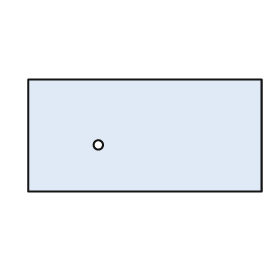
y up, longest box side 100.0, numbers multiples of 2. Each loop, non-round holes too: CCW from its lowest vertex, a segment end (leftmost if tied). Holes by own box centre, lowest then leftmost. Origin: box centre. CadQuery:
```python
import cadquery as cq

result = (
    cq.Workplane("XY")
    .moveTo(-50.0, -24.0)
    .lineTo(50.0, -24.0)
    .lineTo(50.0, 24.0)
    .lineTo(-50.0, 24.0)
    .close()
    .moveTo(-20.0, -4.0)
    .circle(2.0)
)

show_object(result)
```